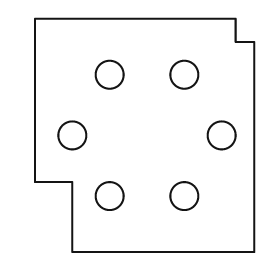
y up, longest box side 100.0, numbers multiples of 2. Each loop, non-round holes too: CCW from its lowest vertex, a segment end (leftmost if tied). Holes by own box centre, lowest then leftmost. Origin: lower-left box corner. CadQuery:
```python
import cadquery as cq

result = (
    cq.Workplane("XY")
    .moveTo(16.0, 0.0)
    .lineTo(94.0, 0.0)
    .lineTo(94.0, 90.0)
    .lineTo(86.0, 90.0)
    .lineTo(86.0, 100.0)
    .lineTo(0.0, 100.0)
    .lineTo(0.0, 30.0)
    .lineTo(16.0, 30.0)
    .close()
    .moveTo(32.0, 24.0)
    .circle(6.0)
    .moveTo(64.0, 24.0)
    .circle(6.0)
    .moveTo(16.0, 50.0)
    .circle(6.0)
    .moveTo(80.0, 50.0)
    .circle(6.0)
    .moveTo(32.0, 76.0)
    .circle(6.0)
    .moveTo(64.0, 76.0)
    .circle(6.0)
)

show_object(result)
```